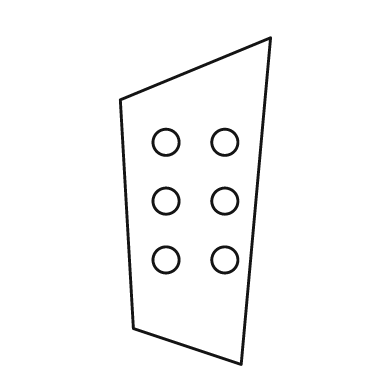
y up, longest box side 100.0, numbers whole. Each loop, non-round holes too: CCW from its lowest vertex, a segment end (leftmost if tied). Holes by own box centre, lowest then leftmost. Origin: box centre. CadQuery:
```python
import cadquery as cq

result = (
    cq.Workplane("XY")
    .moveTo(14.0, -50.0)
    .lineTo(23.0, 50.0)
    .lineTo(-23.0, 31.0)
    .lineTo(-19.0, -39.0)
    .close()
    .moveTo(-9.0, -18.0)
    .circle(4.0)
    .moveTo(9.0, -18.0)
    .circle(4.0)
    .moveTo(-9.0, 0.0)
    .circle(4.0)
    .moveTo(9.0, 0.0)
    .circle(4.0)
    .moveTo(-9.0, 18.0)
    .circle(4.0)
    .moveTo(9.0, 18.0)
    .circle(4.0)
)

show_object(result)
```